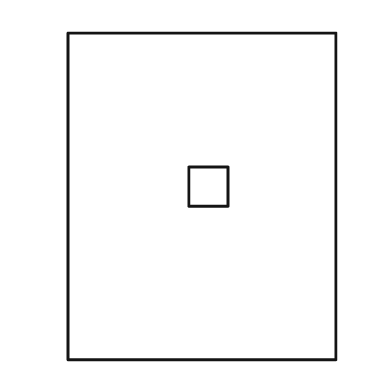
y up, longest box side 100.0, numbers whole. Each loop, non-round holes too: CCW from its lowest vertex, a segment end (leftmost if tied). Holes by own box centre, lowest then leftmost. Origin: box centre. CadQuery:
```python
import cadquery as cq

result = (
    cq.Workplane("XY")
    .moveTo(-41.0, -50.0)
    .lineTo(41.0, -50.0)
    .lineTo(41.0, 50.0)
    .lineTo(-41.0, 50.0)
    .close()
    .moveTo(-4.0, -3.0)
    .lineTo(8.0, -3.0)
    .lineTo(8.0, 9.0)
    .lineTo(-4.0, 9.0)
    .close()
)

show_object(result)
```